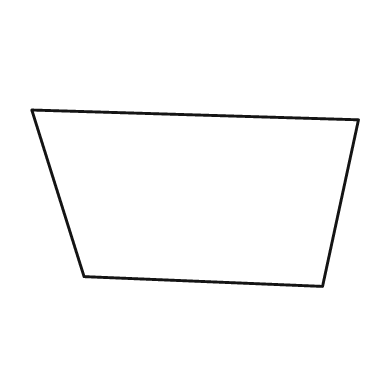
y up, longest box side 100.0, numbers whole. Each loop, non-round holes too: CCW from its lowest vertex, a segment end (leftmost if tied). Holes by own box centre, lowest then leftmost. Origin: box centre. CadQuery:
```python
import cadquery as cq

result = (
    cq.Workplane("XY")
    .moveTo(39.0, -27.0)
    .lineTo(50.0, 24.0)
    .lineTo(-50.0, 27.0)
    .lineTo(-34.0, -24.0)
    .close()
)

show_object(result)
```